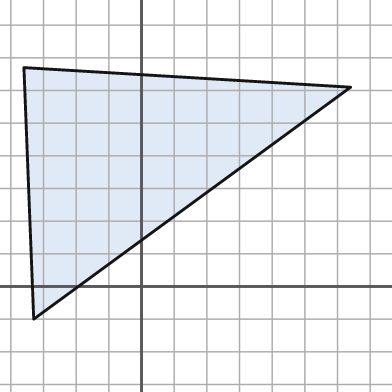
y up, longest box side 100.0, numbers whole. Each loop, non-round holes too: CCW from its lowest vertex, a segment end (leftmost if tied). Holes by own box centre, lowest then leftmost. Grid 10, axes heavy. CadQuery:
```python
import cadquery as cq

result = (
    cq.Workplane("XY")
    .moveTo(-33.0, -10.0)
    .lineTo(64.0, 61.0)
    .lineTo(-36.0, 67.0)
    .close()
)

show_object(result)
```